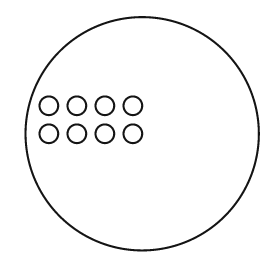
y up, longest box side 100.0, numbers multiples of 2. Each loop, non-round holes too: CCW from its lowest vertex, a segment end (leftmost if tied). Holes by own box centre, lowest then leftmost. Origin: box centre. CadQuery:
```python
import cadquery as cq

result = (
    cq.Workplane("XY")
    .moveTo(0.0, 0.0)
    .circle(50.0)
    .moveTo(-40.0, 0.0)
    .circle(4.0)
    .moveTo(-28.0, 0.0)
    .circle(4.0)
    .moveTo(-16.0, 0.0)
    .circle(4.0)
    .moveTo(-4.0, 0.0)
    .circle(4.0)
    .moveTo(-40.0, 12.0)
    .circle(4.0)
    .moveTo(-28.0, 12.0)
    .circle(4.0)
    .moveTo(-16.0, 12.0)
    .circle(4.0)
    .moveTo(-4.0, 12.0)
    .circle(4.0)
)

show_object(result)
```